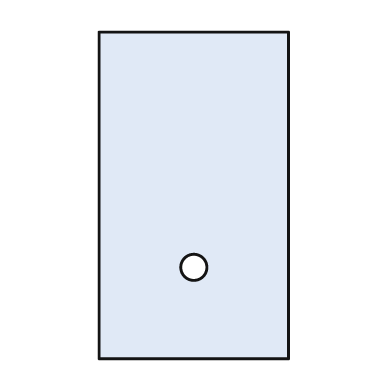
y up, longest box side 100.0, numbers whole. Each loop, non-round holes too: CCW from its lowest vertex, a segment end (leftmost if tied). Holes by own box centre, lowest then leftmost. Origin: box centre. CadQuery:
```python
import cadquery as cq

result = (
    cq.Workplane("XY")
    .moveTo(-29.0, -50.0)
    .lineTo(29.0, -50.0)
    .lineTo(29.0, 50.0)
    .lineTo(-29.0, 50.0)
    .close()
    .moveTo(0.0, -22.0)
    .circle(4.0)
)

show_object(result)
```